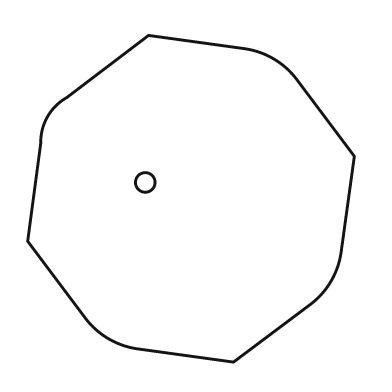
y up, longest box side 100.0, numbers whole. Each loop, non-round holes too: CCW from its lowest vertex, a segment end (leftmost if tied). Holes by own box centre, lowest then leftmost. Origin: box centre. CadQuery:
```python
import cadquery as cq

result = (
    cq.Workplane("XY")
    .moveTo(13.0, -50.0)
    .lineTo(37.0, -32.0)
    .threePointArc((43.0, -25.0), (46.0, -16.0))
    .lineTo(50.0, 13.0)
    .lineTo(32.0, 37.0)
    .threePointArc((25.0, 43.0), (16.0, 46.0))
    .lineTo(-13.0, 50.0)
    .lineTo(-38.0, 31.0)
    .threePointArc((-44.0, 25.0), (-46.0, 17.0))
    .lineTo(-50.0, -13.0)
    .lineTo(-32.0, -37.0)
    .threePointArc((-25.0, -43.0), (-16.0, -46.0))
    .close()
    .moveTo(-14.0, 5.0)
    .circle(3.0)
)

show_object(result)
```